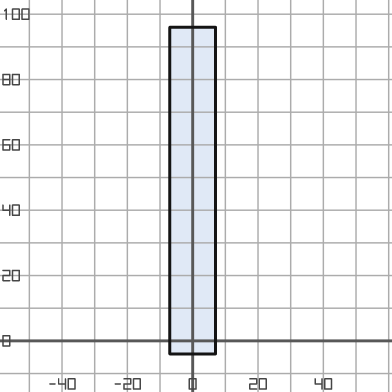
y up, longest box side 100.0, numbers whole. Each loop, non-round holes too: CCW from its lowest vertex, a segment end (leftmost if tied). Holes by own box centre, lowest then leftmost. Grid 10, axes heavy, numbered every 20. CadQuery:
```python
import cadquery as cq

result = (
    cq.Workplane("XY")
    .moveTo(-7.0, -4.0)
    .lineTo(7.0, -4.0)
    .lineTo(7.0, 96.0)
    .lineTo(-7.0, 96.0)
    .close()
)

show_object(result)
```